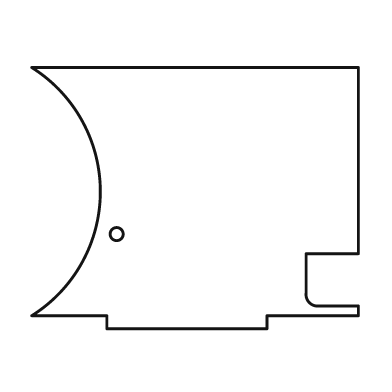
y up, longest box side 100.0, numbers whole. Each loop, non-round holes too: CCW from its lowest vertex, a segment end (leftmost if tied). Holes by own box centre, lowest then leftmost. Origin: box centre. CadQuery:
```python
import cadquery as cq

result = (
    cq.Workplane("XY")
    .moveTo(-27.0, -40.0)
    .lineTo(22.0, -40.0)
    .lineTo(22.0, -36.0)
    .lineTo(50.0, -36.0)
    .lineTo(50.0, -33.0)
    .lineTo(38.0, -33.0)
    .threePointArc((35.0, -32.0), (34.0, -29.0))
    .lineTo(34.0, -17.0)
    .lineTo(50.0, -17.0)
    .lineTo(50.0, 40.0)
    .lineTo(-50.0, 40.0)
    .threePointArc((-29.0, 2.0), (-50.0, -36.0))
    .lineTo(-27.0, -36.0)
    .close()
    .moveTo(-24.0, -11.0)
    .circle(2.0)
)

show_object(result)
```